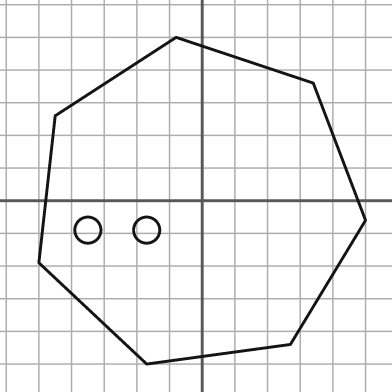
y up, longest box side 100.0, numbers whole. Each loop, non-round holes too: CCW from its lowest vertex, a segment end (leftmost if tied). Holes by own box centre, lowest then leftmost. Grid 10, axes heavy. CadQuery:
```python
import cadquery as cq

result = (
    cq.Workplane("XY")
    .moveTo(-17.0, -50.0)
    .lineTo(27.0, -44.0)
    .lineTo(50.0, -6.0)
    .lineTo(34.0, 36.0)
    .lineTo(-8.0, 50.0)
    .lineTo(-45.0, 26.0)
    .lineTo(-50.0, -19.0)
    .close()
    .moveTo(-35.0, -9.0)
    .circle(4.0)
    .moveTo(-17.0, -9.0)
    .circle(4.0)
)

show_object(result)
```